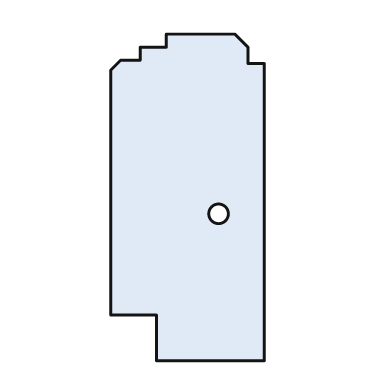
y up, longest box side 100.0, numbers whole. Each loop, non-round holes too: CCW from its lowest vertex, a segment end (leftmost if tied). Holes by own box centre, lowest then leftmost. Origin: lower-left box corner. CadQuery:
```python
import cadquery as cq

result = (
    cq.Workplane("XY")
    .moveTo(14.0, 0.0)
    .lineTo(47.0, 0.0)
    .lineTo(47.0, 91.0)
    .lineTo(42.0, 91.0)
    .lineTo(42.0, 96.0)
    .lineTo(38.0, 100.0)
    .lineTo(17.0, 100.0)
    .lineTo(17.0, 96.0)
    .lineTo(9.0, 96.0)
    .lineTo(9.0, 92.0)
    .lineTo(3.0, 92.0)
    .lineTo(0.0, 89.0)
    .lineTo(0.0, 14.0)
    .lineTo(14.0, 14.0)
    .close()
    .moveTo(33.0, 45.0)
    .circle(3.0)
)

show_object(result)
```